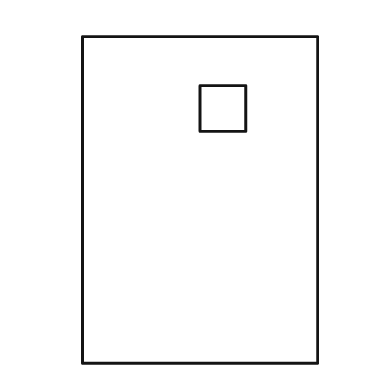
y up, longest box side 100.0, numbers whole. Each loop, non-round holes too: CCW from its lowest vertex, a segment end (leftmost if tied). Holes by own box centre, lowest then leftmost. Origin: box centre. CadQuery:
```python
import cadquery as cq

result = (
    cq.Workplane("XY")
    .moveTo(-36.0, -50.0)
    .lineTo(36.0, -50.0)
    .lineTo(36.0, 50.0)
    .lineTo(-36.0, 50.0)
    .close()
    .moveTo(0.0, 21.0)
    .lineTo(14.0, 21.0)
    .lineTo(14.0, 35.0)
    .lineTo(0.0, 35.0)
    .close()
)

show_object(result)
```